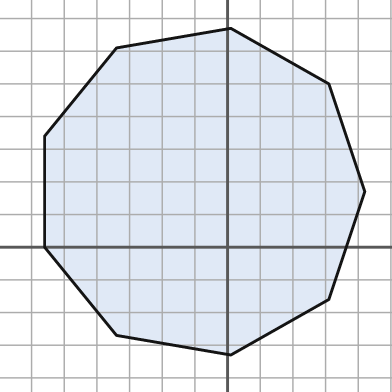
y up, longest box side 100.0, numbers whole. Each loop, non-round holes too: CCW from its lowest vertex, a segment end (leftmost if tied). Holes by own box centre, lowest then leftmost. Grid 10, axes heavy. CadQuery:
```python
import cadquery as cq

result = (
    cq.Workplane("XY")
    .moveTo(1.0, -33.0)
    .lineTo(31.0, -16.0)
    .lineTo(42.0, 17.0)
    .lineTo(31.0, 50.0)
    .lineTo(1.0, 67.0)
    .lineTo(-34.0, 61.0)
    .lineTo(-56.0, 34.0)
    .lineTo(-56.0, 0.0)
    .lineTo(-34.0, -27.0)
    .close()
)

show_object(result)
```